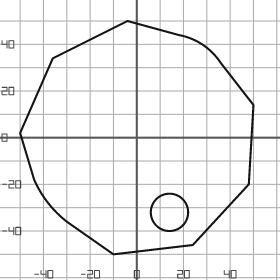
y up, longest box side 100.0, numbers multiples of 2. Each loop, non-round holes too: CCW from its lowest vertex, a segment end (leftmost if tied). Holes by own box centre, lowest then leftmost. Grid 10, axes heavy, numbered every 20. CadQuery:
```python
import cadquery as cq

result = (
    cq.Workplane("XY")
    .moveTo(-10.0, -50.0)
    .lineTo(24.0, -46.0)
    .lineTo(48.0, -20.0)
    .lineTo(50.0, 14.0)
    .lineTo(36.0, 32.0)
    .threePointArc((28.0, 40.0), (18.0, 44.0))
    .lineTo(-4.0, 50.0)
    .lineTo(-36.0, 34.0)
    .lineTo(-50.0, 2.0)
    .lineTo(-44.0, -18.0)
    .threePointArc((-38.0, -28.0), (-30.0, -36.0))
    .close()
    .moveTo(14.0, -32.0)
    .circle(8.0)
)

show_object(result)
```